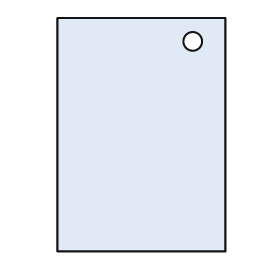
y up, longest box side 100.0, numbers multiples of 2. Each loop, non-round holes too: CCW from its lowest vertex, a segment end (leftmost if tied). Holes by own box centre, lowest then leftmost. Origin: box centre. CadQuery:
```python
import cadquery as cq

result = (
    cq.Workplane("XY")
    .moveTo(-36.0, -50.0)
    .lineTo(36.0, -50.0)
    .lineTo(36.0, 50.0)
    .lineTo(-36.0, 50.0)
    .close()
    .moveTo(22.0, 40.0)
    .circle(4.0)
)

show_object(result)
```